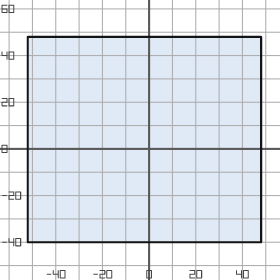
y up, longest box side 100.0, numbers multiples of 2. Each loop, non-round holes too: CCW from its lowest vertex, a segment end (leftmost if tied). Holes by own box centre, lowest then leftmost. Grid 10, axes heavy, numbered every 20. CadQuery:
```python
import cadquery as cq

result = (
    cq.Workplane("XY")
    .moveTo(-52.0, -40.0)
    .lineTo(48.0, -40.0)
    .lineTo(48.0, 48.0)
    .lineTo(-52.0, 48.0)
    .close()
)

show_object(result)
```